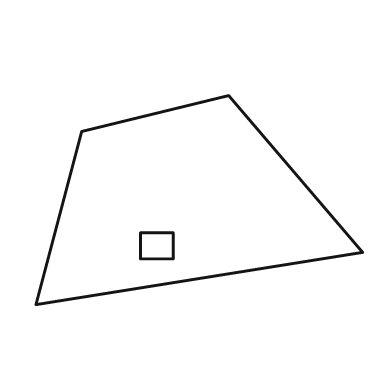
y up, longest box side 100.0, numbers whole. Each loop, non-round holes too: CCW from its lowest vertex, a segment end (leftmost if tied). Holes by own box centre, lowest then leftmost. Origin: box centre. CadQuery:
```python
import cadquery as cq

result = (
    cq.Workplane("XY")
    .moveTo(-50.0, -32.0)
    .lineTo(50.0, -16.0)
    .lineTo(9.0, 32.0)
    .lineTo(-36.0, 21.0)
    .close()
    .moveTo(-18.0, -18.0)
    .lineTo(-8.0, -18.0)
    .lineTo(-8.0, -10.0)
    .lineTo(-18.0, -10.0)
    .close()
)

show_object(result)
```